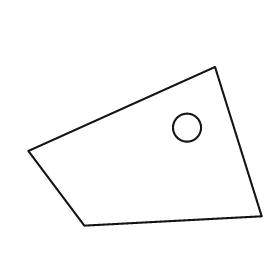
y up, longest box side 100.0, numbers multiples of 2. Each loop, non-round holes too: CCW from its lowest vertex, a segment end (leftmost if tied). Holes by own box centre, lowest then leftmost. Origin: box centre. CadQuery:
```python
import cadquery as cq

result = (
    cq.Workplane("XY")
    .moveTo(-26.0, -34.0)
    .lineTo(50.0, -30.0)
    .lineTo(30.0, 34.0)
    .lineTo(-50.0, -2.0)
    .close()
    .moveTo(18.0, 8.0)
    .circle(6.0)
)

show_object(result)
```